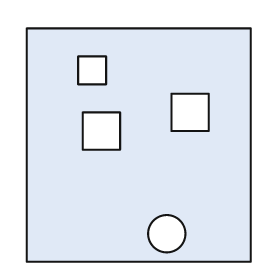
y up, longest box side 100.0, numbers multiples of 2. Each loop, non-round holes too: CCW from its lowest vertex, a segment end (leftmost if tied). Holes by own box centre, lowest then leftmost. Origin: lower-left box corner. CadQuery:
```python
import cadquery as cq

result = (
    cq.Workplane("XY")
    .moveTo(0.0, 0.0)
    .lineTo(96.0, 0.0)
    .lineTo(96.0, 100.0)
    .lineTo(0.0, 100.0)
    .close()
    .moveTo(60.0, 12.0)
    .circle(8.0)
    .moveTo(24.0, 48.0)
    .lineTo(40.0, 48.0)
    .lineTo(40.0, 64.0)
    .lineTo(24.0, 64.0)
    .close()
    .moveTo(62.0, 56.0)
    .lineTo(78.0, 56.0)
    .lineTo(78.0, 72.0)
    .lineTo(62.0, 72.0)
    .close()
    .moveTo(22.0, 76.0)
    .lineTo(34.0, 76.0)
    .lineTo(34.0, 88.0)
    .lineTo(22.0, 88.0)
    .close()
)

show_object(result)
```